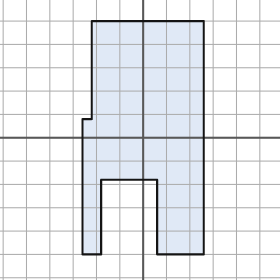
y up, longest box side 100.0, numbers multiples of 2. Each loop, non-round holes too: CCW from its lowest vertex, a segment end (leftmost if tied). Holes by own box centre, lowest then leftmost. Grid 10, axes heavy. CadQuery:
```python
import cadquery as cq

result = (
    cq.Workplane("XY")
    .moveTo(-26.0, -50.0)
    .lineTo(-18.0, -50.0)
    .lineTo(-18.0, -18.0)
    .lineTo(6.0, -18.0)
    .lineTo(6.0, -50.0)
    .lineTo(26.0, -50.0)
    .lineTo(26.0, 50.0)
    .lineTo(-22.0, 50.0)
    .lineTo(-22.0, 8.0)
    .lineTo(-26.0, 8.0)
    .close()
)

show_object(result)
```